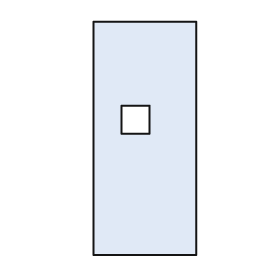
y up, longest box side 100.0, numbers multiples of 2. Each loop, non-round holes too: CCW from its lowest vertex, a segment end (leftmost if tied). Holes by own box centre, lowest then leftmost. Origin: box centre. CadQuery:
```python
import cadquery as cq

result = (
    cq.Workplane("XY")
    .moveTo(-22.0, -50.0)
    .lineTo(22.0, -50.0)
    .lineTo(22.0, 50.0)
    .lineTo(-22.0, 50.0)
    .close()
    .moveTo(-10.0, 2.0)
    .lineTo(2.0, 2.0)
    .lineTo(2.0, 14.0)
    .lineTo(-10.0, 14.0)
    .close()
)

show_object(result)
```